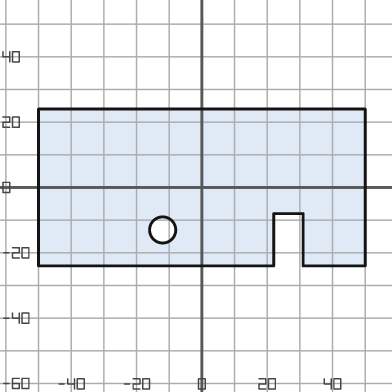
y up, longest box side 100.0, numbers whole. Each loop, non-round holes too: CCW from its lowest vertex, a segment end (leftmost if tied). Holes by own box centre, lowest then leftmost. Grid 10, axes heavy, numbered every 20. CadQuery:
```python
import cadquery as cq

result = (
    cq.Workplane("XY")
    .moveTo(-50.0, -24.0)
    .lineTo(22.0, -24.0)
    .lineTo(22.0, -8.0)
    .lineTo(31.0, -8.0)
    .lineTo(31.0, -24.0)
    .lineTo(50.0, -24.0)
    .lineTo(50.0, 24.0)
    .lineTo(-50.0, 24.0)
    .close()
    .moveTo(-12.0, -13.0)
    .circle(4.0)
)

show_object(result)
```